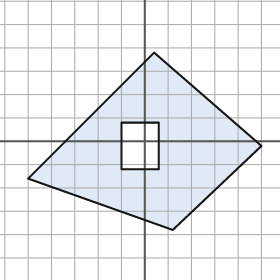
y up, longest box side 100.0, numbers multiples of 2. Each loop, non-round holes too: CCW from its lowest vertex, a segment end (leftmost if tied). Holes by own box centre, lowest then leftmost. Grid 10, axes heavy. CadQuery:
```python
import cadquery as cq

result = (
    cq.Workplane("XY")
    .moveTo(12.0, -38.0)
    .lineTo(50.0, -2.0)
    .lineTo(4.0, 38.0)
    .lineTo(-50.0, -16.0)
    .close()
    .moveTo(-10.0, -12.0)
    .lineTo(6.0, -12.0)
    .lineTo(6.0, 8.0)
    .lineTo(-10.0, 8.0)
    .close()
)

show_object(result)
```